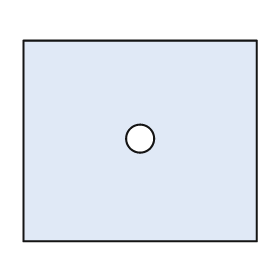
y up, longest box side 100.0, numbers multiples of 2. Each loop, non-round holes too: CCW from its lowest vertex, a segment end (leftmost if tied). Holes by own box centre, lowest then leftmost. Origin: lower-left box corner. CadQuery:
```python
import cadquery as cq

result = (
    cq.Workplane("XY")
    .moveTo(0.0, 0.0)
    .lineTo(100.0, 0.0)
    .lineTo(100.0, 86.0)
    .lineTo(0.0, 86.0)
    .close()
    .moveTo(50.0, 44.0)
    .circle(6.0)
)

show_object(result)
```